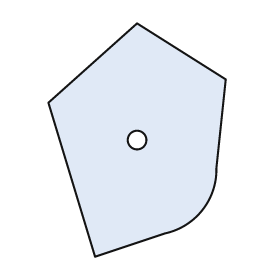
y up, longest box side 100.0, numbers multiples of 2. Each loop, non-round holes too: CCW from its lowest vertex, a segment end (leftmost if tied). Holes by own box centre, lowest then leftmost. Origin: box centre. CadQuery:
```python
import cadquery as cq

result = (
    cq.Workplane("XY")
    .moveTo(-18.0, -50.0)
    .lineTo(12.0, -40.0)
    .threePointArc((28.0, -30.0), (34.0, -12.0))
    .lineTo(38.0, 26.0)
    .lineTo(0.0, 50.0)
    .lineTo(-38.0, 16.0)
    .close()
    .moveTo(0.0, 0.0)
    .circle(4.0)
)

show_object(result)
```